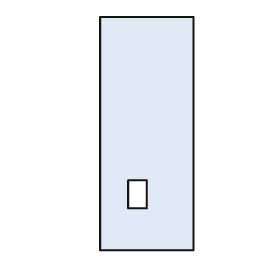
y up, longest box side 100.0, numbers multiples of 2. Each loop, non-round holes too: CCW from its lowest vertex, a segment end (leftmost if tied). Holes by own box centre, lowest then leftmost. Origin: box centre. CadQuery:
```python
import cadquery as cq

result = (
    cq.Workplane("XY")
    .moveTo(-20.0, -50.0)
    .lineTo(20.0, -50.0)
    .lineTo(20.0, 50.0)
    .lineTo(-20.0, 50.0)
    .close()
    .moveTo(-8.0, -32.0)
    .lineTo(0.0, -32.0)
    .lineTo(0.0, -20.0)
    .lineTo(-8.0, -20.0)
    .close()
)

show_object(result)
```